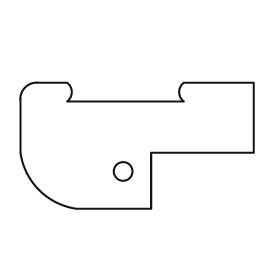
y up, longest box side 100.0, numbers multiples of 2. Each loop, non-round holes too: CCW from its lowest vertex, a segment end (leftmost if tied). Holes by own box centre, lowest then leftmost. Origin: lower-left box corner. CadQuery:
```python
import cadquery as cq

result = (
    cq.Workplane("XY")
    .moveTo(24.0, 0.0)
    .lineTo(56.0, 0.0)
    .lineTo(56.0, 24.0)
    .lineTo(100.0, 24.0)
    .lineTo(100.0, 54.0)
    .lineTo(70.0, 54.0)
    .threePointArc((68.0, 50.0), (70.0, 46.0))
    .lineTo(20.0, 46.0)
    .threePointArc((22.0, 50.0), (20.0, 54.0))
    .lineTo(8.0, 54.0)
    .threePointArc((2.0, 52.0), (0.0, 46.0))
    .lineTo(0.0, 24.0)
    .threePointArc((8.0, 8.0), (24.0, 0.0))
    .close()
    .moveTo(44.0, 16.0)
    .circle(4.0)
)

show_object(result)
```